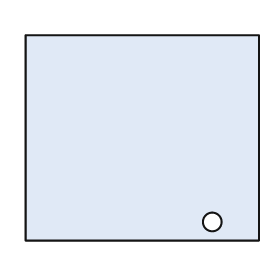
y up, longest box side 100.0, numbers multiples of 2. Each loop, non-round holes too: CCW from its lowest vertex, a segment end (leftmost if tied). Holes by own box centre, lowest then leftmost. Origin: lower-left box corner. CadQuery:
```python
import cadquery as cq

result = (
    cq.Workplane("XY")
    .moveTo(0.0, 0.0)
    .lineTo(100.0, 0.0)
    .lineTo(100.0, 88.0)
    .lineTo(0.0, 88.0)
    .close()
    .moveTo(80.0, 8.0)
    .circle(4.0)
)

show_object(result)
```